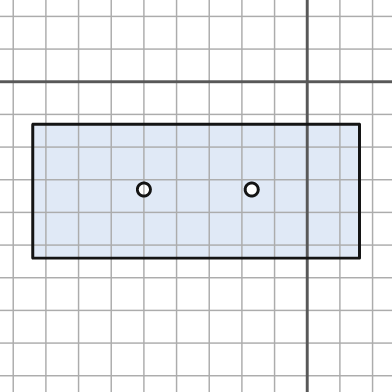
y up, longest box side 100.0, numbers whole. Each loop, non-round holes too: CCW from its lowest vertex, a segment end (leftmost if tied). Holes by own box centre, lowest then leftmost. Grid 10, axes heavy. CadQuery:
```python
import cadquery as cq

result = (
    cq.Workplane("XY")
    .moveTo(-84.0, -54.0)
    .lineTo(16.0, -54.0)
    .lineTo(16.0, -13.0)
    .lineTo(-84.0, -13.0)
    .close()
    .moveTo(-50.0, -33.0)
    .circle(2.0)
    .moveTo(-17.0, -33.0)
    .circle(2.0)
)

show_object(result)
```